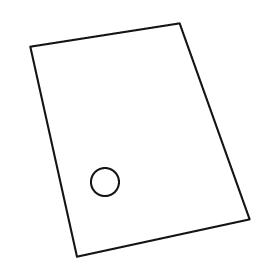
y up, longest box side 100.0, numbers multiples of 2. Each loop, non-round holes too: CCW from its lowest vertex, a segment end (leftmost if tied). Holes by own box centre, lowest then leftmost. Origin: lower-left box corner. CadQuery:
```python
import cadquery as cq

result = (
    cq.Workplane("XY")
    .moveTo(20.0, 0.0)
    .lineTo(94.0, 16.0)
    .lineTo(64.0, 100.0)
    .lineTo(0.0, 90.0)
    .close()
    .moveTo(32.0, 32.0)
    .circle(6.0)
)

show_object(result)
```